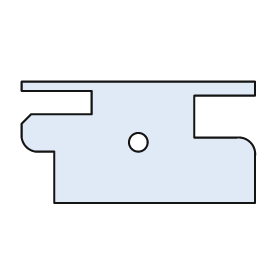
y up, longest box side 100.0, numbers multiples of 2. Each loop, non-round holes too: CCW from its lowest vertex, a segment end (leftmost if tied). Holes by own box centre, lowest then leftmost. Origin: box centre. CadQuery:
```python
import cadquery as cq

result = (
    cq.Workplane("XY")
    .moveTo(-36.0, -26.0)
    .lineTo(50.0, -26.0)
    .lineTo(50.0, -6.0)
    .threePointArc((48.0, 0.0), (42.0, 2.0))
    .lineTo(24.0, 2.0)
    .lineTo(24.0, 20.0)
    .lineTo(50.0, 20.0)
    .lineTo(50.0, 26.0)
    .lineTo(-50.0, 26.0)
    .lineTo(-50.0, 22.0)
    .lineTo(-20.0, 22.0)
    .lineTo(-20.0, 12.0)
    .lineTo(-46.0, 12.0)
    .lineTo(-50.0, 8.0)
    .lineTo(-50.0, 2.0)
    .threePointArc((-48.0, -2.0), (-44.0, -4.0))
    .lineTo(-36.0, -4.0)
    .close()
    .moveTo(0.0, 0.0)
    .circle(4.0)
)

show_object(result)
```